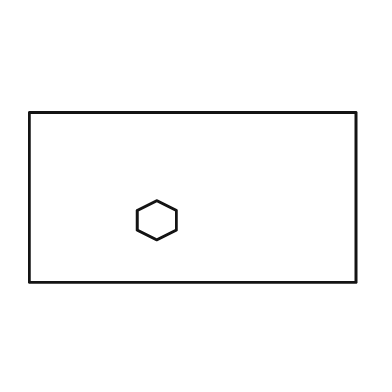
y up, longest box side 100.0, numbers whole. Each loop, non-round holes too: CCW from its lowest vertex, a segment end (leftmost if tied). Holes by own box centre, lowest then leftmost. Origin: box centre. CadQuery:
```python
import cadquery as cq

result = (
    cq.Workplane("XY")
    .moveTo(-50.0, -26.0)
    .lineTo(50.0, -26.0)
    .lineTo(50.0, 26.0)
    .lineTo(-50.0, 26.0)
    .close()
    .moveTo(-11.0, -13.0)
    .lineTo(-5.0, -10.0)
    .lineTo(-5.0, -4.0)
    .lineTo(-11.0, -1.0)
    .lineTo(-17.0, -4.0)
    .lineTo(-17.0, -10.0)
    .close()
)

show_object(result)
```